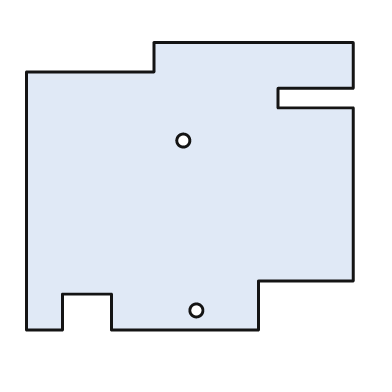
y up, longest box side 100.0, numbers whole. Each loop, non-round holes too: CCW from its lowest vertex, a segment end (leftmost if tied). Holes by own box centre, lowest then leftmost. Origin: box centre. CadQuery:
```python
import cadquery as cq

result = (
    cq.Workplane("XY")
    .moveTo(-50.0, -44.0)
    .lineTo(-39.0, -44.0)
    .lineTo(-39.0, -33.0)
    .lineTo(-24.0, -33.0)
    .lineTo(-24.0, -44.0)
    .lineTo(21.0, -44.0)
    .lineTo(21.0, -29.0)
    .lineTo(50.0, -29.0)
    .lineTo(50.0, 24.0)
    .lineTo(27.0, 24.0)
    .lineTo(27.0, 30.0)
    .lineTo(50.0, 30.0)
    .lineTo(50.0, 44.0)
    .lineTo(-11.0, 44.0)
    .lineTo(-11.0, 35.0)
    .lineTo(-50.0, 35.0)
    .close()
    .moveTo(2.0, -38.0)
    .circle(2.0)
    .moveTo(-2.0, 14.0)
    .circle(2.0)
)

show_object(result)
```